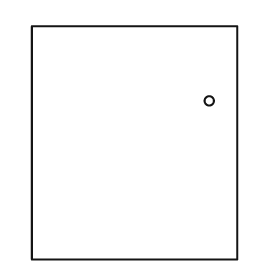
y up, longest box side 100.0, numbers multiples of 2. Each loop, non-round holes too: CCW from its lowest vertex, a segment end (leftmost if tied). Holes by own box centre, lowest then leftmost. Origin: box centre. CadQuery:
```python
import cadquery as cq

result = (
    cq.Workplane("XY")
    .moveTo(-44.0, -50.0)
    .lineTo(44.0, -50.0)
    .lineTo(44.0, 50.0)
    .lineTo(-44.0, 50.0)
    .close()
    .moveTo(32.0, 18.0)
    .circle(2.0)
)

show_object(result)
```